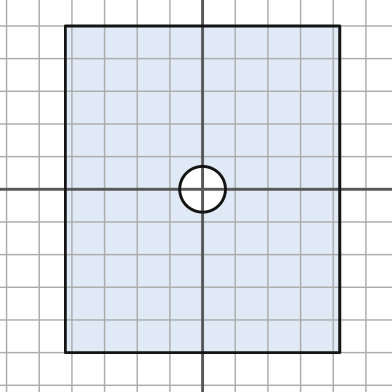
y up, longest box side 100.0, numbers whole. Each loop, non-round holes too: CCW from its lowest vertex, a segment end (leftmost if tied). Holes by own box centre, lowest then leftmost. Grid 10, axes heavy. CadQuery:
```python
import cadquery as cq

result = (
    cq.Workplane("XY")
    .moveTo(-42.0, -50.0)
    .lineTo(42.0, -50.0)
    .lineTo(42.0, 50.0)
    .lineTo(-42.0, 50.0)
    .close()
    .moveTo(0.0, 0.0)
    .circle(7.0)
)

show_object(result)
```